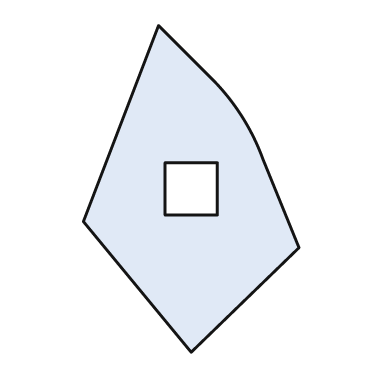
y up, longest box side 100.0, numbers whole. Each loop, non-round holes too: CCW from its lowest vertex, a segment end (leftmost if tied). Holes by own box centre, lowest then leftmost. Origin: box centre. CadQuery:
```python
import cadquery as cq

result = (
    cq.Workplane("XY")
    .moveTo(0.0, -50.0)
    .lineTo(33.0, -18.0)
    .lineTo(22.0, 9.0)
    .threePointArc((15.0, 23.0), (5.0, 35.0))
    .lineTo(-10.0, 50.0)
    .lineTo(-33.0, -10.0)
    .close()
    .moveTo(-8.0, -8.0)
    .lineTo(8.0, -8.0)
    .lineTo(8.0, 8.0)
    .lineTo(-8.0, 8.0)
    .close()
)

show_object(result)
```